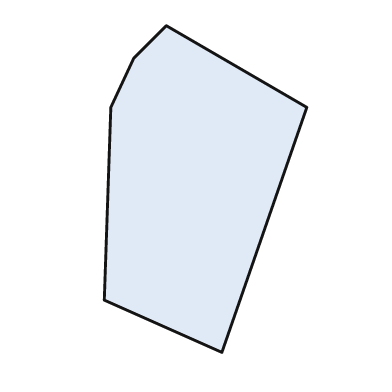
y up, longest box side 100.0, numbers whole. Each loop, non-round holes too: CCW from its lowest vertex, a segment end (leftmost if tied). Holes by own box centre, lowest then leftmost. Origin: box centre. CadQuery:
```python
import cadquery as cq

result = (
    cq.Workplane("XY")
    .moveTo(5.0, -50.0)
    .lineTo(31.0, 25.0)
    .lineTo(-12.0, 50.0)
    .lineTo(-22.0, 40.0)
    .lineTo(-29.0, 25.0)
    .lineTo(-31.0, -34.0)
    .close()
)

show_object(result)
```